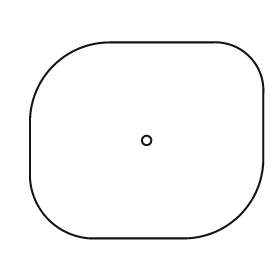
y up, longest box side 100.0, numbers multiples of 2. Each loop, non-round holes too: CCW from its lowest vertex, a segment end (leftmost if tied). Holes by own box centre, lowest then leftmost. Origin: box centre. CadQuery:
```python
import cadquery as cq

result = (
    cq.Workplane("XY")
    .moveTo(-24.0, -42.0)
    .lineTo(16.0, -42.0)
    .threePointArc((40.0, -32.0), (50.0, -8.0))
    .lineTo(50.0, 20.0)
    .threePointArc((44.0, 36.0), (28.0, 42.0))
    .lineTo(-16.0, 42.0)
    .threePointArc((-40.0, 32.0), (-50.0, 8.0))
    .lineTo(-50.0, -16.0)
    .threePointArc((-42.0, -34.0), (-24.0, -42.0))
    .close()
    .moveTo(0.0, 0.0)
    .circle(2.0)
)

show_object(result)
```